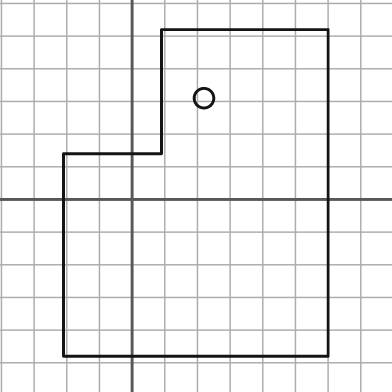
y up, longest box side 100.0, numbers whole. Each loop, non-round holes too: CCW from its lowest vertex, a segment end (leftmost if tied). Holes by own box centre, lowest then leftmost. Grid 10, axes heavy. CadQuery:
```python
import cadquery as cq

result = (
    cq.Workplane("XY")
    .moveTo(-21.0, -48.0)
    .lineTo(60.0, -48.0)
    .lineTo(60.0, 52.0)
    .lineTo(9.0, 52.0)
    .lineTo(9.0, 14.0)
    .lineTo(-21.0, 14.0)
    .close()
    .moveTo(22.0, 31.0)
    .circle(3.0)
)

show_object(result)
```